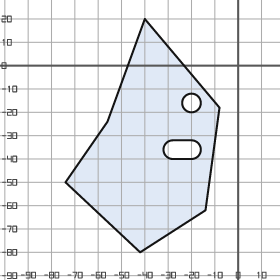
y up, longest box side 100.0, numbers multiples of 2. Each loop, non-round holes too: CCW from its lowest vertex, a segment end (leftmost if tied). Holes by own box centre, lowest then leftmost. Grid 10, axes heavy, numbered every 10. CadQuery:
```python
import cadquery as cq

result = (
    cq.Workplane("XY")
    .moveTo(-42.0, -80.0)
    .lineTo(-14.0, -62.0)
    .lineTo(-8.0, -18.0)
    .lineTo(-40.0, 20.0)
    .lineTo(-56.0, -24.0)
    .lineTo(-74.0, -50.0)
    .close()
    .moveTo(-28.0, -40.0)
    .lineTo(-20.0, -40.0)
    .threePointArc((-16.0, -36.0), (-20.0, -32.0))
    .lineTo(-28.0, -32.0)
    .threePointArc((-32.0, -36.0), (-28.0, -40.0))
    .close()
    .moveTo(-20.0, -16.0)
    .circle(4.0)
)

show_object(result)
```